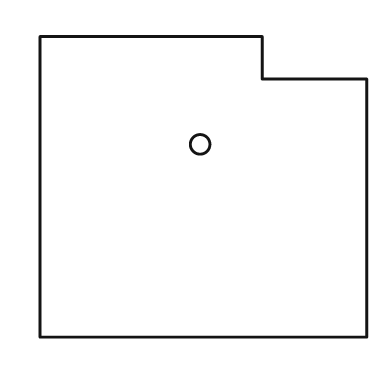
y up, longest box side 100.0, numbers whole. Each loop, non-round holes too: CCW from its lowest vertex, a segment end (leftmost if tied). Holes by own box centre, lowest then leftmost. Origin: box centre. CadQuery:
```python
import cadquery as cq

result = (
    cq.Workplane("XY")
    .moveTo(-50.0, -46.0)
    .lineTo(50.0, -46.0)
    .lineTo(50.0, 33.0)
    .lineTo(18.0, 33.0)
    .lineTo(18.0, 46.0)
    .lineTo(-50.0, 46.0)
    .close()
    .moveTo(-1.0, 13.0)
    .circle(3.0)
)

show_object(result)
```